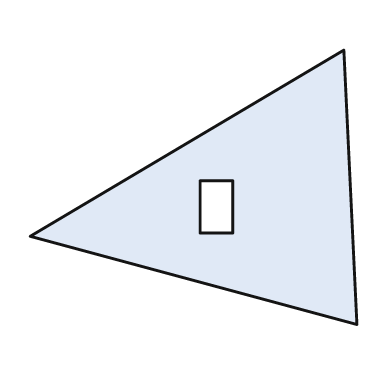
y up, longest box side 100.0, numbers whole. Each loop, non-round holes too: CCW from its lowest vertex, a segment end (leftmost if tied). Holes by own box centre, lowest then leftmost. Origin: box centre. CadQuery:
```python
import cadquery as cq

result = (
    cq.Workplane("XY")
    .moveTo(50.0, -42.0)
    .lineTo(46.0, 42.0)
    .lineTo(-50.0, -15.0)
    .close()
    .moveTo(2.0, -14.0)
    .lineTo(12.0, -14.0)
    .lineTo(12.0, 2.0)
    .lineTo(2.0, 2.0)
    .close()
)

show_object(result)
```